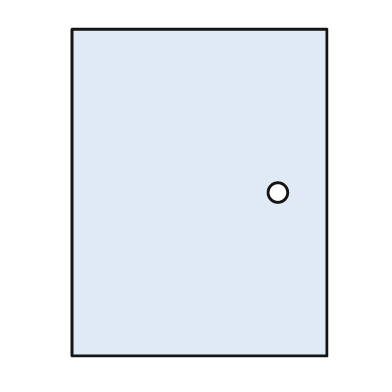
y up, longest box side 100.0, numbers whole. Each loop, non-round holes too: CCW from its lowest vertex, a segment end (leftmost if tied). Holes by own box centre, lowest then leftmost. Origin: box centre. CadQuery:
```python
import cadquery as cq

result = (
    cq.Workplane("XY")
    .moveTo(-39.0, -50.0)
    .lineTo(39.0, -50.0)
    .lineTo(39.0, 50.0)
    .lineTo(-39.0, 50.0)
    .close()
    .moveTo(24.0, 0.0)
    .circle(3.0)
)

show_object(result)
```